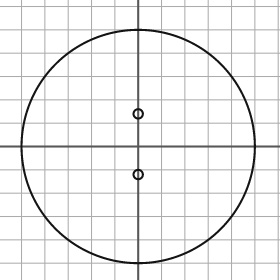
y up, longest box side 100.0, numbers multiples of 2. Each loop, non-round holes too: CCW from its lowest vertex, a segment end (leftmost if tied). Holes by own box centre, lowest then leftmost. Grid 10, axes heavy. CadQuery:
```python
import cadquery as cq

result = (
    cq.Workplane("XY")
    .moveTo(0.0, 0.0)
    .circle(50.0)
    .moveTo(0.0, -12.0)
    .circle(2.0)
    .moveTo(0.0, 14.0)
    .circle(2.0)
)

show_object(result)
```